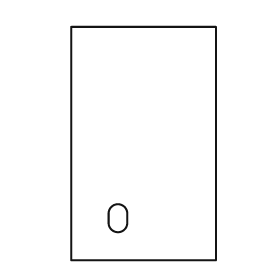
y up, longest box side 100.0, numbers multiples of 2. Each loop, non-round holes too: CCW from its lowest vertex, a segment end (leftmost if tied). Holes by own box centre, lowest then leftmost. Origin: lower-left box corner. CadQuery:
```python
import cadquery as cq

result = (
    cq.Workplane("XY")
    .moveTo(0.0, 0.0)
    .lineTo(62.0, 0.0)
    .lineTo(62.0, 100.0)
    .lineTo(0.0, 100.0)
    .close()
    .moveTo(16.0, 16.0)
    .threePointArc((20.0, 12.0), (24.0, 16.0))
    .lineTo(24.0, 20.0)
    .threePointArc((20.0, 24.0), (16.0, 20.0))
    .close()
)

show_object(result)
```